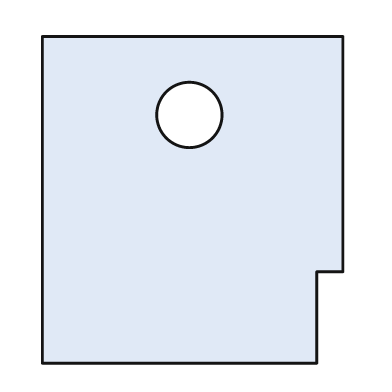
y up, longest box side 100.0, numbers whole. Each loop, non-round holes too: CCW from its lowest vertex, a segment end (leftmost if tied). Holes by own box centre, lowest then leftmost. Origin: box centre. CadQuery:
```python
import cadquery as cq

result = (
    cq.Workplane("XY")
    .moveTo(-46.0, -50.0)
    .lineTo(38.0, -50.0)
    .lineTo(38.0, -22.0)
    .lineTo(46.0, -22.0)
    .lineTo(46.0, 50.0)
    .lineTo(-46.0, 50.0)
    .close()
    .moveTo(-1.0, 26.0)
    .circle(10.0)
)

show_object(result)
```